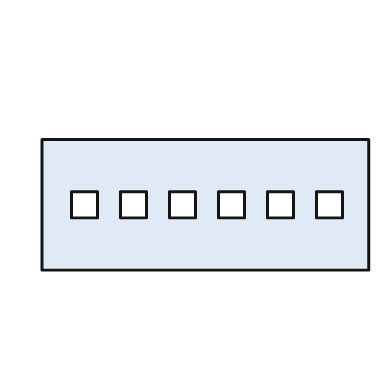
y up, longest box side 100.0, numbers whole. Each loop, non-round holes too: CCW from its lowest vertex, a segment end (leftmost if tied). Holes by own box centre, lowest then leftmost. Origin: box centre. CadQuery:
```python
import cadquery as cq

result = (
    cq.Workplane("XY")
    .moveTo(-50.0, -20.0)
    .lineTo(50.0, -20.0)
    .lineTo(50.0, 20.0)
    .lineTo(-50.0, 20.0)
    .close()
    .moveTo(-41.0, -4.0)
    .lineTo(-33.0, -4.0)
    .lineTo(-33.0, 4.0)
    .lineTo(-41.0, 4.0)
    .close()
    .moveTo(-26.0, -4.0)
    .lineTo(-18.0, -4.0)
    .lineTo(-18.0, 4.0)
    .lineTo(-26.0, 4.0)
    .close()
    .moveTo(-11.0, -4.0)
    .lineTo(-3.0, -4.0)
    .lineTo(-3.0, 4.0)
    .lineTo(-11.0, 4.0)
    .close()
    .moveTo(4.0, -4.0)
    .lineTo(12.0, -4.0)
    .lineTo(12.0, 4.0)
    .lineTo(4.0, 4.0)
    .close()
    .moveTo(19.0, -4.0)
    .lineTo(27.0, -4.0)
    .lineTo(27.0, 4.0)
    .lineTo(19.0, 4.0)
    .close()
    .moveTo(34.0, -4.0)
    .lineTo(42.0, -4.0)
    .lineTo(42.0, 4.0)
    .lineTo(34.0, 4.0)
    .close()
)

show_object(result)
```